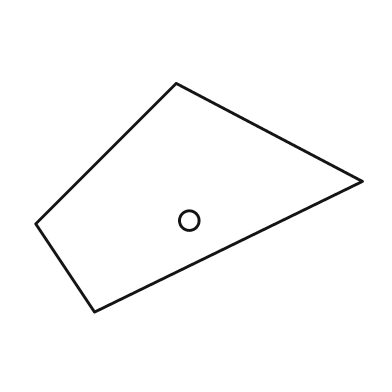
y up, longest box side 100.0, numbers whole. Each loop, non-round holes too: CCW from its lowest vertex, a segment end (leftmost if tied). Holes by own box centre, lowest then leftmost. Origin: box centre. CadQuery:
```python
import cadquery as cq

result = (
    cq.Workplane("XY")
    .moveTo(-32.0, -35.0)
    .lineTo(50.0, 5.0)
    .lineTo(-7.0, 35.0)
    .lineTo(-50.0, -8.0)
    .close()
    .moveTo(-3.0, -7.0)
    .circle(3.0)
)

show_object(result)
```